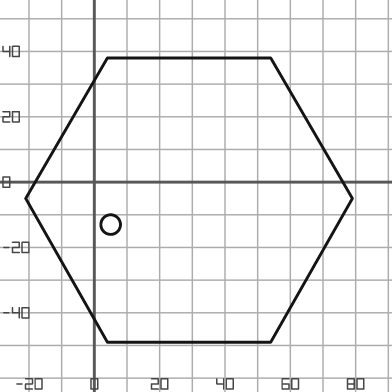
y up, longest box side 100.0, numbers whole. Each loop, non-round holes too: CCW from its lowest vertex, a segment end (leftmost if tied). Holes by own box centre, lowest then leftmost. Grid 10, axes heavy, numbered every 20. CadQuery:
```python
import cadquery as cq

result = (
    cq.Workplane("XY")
    .moveTo(4.0, -49.0)
    .lineTo(54.0, -49.0)
    .lineTo(79.0, -5.0)
    .lineTo(54.0, 38.0)
    .lineTo(4.0, 38.0)
    .lineTo(-21.0, -5.0)
    .close()
    .moveTo(5.0, -13.0)
    .circle(3.0)
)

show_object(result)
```